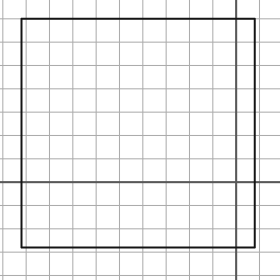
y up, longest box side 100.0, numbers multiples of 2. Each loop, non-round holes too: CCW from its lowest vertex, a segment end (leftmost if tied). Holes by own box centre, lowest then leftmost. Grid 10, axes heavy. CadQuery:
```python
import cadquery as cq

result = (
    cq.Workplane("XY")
    .moveTo(-92.0, -28.0)
    .lineTo(8.0, -28.0)
    .lineTo(8.0, 70.0)
    .lineTo(-92.0, 70.0)
    .close()
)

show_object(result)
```